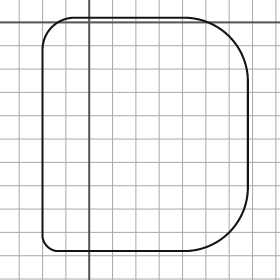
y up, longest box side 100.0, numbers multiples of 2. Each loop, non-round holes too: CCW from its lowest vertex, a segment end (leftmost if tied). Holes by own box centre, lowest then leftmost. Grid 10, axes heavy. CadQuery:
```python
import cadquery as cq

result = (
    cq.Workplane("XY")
    .moveTo(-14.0, -98.0)
    .lineTo(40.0, -98.0)
    .threePointArc((60.0, -90.0), (68.0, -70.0))
    .lineTo(68.0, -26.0)
    .threePointArc((60.0, -6.0), (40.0, 2.0))
    .lineTo(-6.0, 2.0)
    .threePointArc((-16.0, -2.0), (-20.0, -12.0))
    .lineTo(-20.0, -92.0)
    .threePointArc((-18.0, -96.0), (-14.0, -98.0))
    .close()
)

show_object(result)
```